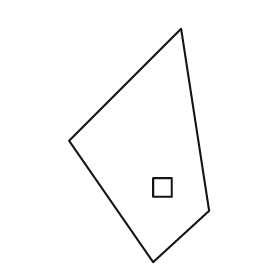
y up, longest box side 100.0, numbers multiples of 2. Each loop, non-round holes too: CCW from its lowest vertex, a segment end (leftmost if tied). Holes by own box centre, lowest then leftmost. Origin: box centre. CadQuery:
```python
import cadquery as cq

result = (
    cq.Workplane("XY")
    .moveTo(6.0, -50.0)
    .lineTo(30.0, -28.0)
    .lineTo(18.0, 50.0)
    .lineTo(-30.0, 2.0)
    .close()
    .moveTo(6.0, -22.0)
    .lineTo(14.0, -22.0)
    .lineTo(14.0, -14.0)
    .lineTo(6.0, -14.0)
    .close()
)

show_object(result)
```